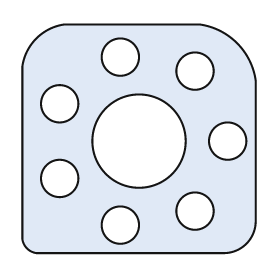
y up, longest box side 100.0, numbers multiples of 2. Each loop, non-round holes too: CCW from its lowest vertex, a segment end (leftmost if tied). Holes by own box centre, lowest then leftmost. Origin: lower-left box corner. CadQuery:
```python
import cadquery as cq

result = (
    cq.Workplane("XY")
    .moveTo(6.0, 0.0)
    .lineTo(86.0, 0.0)
    .threePointArc((96.0, 4.0), (100.0, 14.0))
    .lineTo(100.0, 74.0)
    .threePointArc((92.0, 90.0), (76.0, 98.0))
    .lineTo(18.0, 98.0)
    .threePointArc((6.0, 92.0), (0.0, 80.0))
    .lineTo(0.0, 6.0)
    .threePointArc((2.0, 2.0), (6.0, 0.0))
    .close()
    .moveTo(42.0, 12.0)
    .circle(8.0)
    .moveTo(74.0, 18.0)
    .circle(8.0)
    .moveTo(16.0, 32.0)
    .circle(8.0)
    .moveTo(50.0, 48.0)
    .circle(20.0)
    .moveTo(88.0, 48.0)
    .circle(8.0)
    .moveTo(16.0, 64.0)
    .circle(8.0)
    .moveTo(74.0, 78.0)
    .circle(8.0)
    .moveTo(42.0, 84.0)
    .circle(8.0)
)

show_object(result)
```